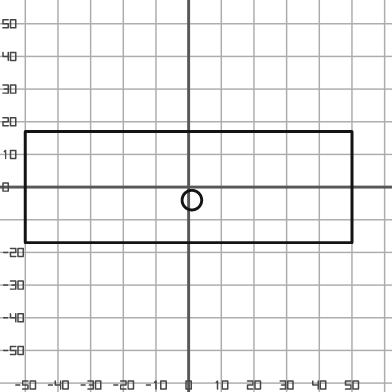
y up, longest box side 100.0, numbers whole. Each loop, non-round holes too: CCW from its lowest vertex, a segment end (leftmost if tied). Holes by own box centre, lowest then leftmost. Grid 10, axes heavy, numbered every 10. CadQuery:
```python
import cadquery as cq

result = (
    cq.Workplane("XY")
    .moveTo(-50.0, -17.0)
    .lineTo(50.0, -17.0)
    .lineTo(50.0, 17.0)
    .lineTo(-50.0, 17.0)
    .close()
    .moveTo(1.0, -4.0)
    .circle(3.0)
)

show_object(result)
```